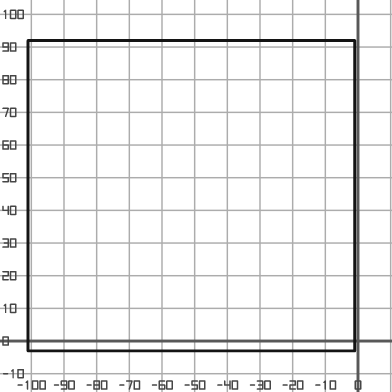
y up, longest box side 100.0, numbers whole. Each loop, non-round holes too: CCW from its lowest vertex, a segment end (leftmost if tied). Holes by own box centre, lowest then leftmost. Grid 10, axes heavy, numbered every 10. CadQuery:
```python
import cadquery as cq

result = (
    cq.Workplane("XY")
    .moveTo(-101.0, -3.0)
    .lineTo(-1.0, -3.0)
    .lineTo(-1.0, 92.0)
    .lineTo(-101.0, 92.0)
    .close()
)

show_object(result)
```